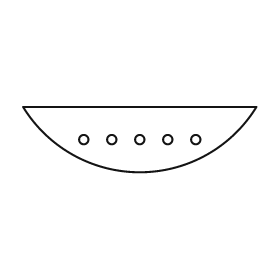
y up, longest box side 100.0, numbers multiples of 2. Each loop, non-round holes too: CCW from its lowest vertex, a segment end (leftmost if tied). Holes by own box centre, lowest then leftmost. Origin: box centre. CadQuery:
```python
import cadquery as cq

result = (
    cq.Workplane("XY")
    .moveTo(-50.0, 14.0)
    .threePointArc((0.0, -14.0), (50.0, 14.0))
    .close()
    .moveTo(-24.0, 0.0)
    .circle(2.0)
    .moveTo(-12.0, 0.0)
    .circle(2.0)
    .moveTo(0.0, 0.0)
    .circle(2.0)
    .moveTo(12.0, 0.0)
    .circle(2.0)
    .moveTo(24.0, 0.0)
    .circle(2.0)
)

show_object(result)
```